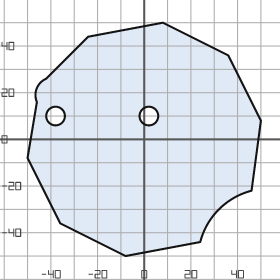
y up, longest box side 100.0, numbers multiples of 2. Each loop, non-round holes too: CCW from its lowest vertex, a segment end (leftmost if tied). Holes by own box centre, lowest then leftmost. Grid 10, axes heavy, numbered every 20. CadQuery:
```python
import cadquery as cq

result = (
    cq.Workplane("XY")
    .moveTo(-8.0, -50.0)
    .lineTo(24.0, -44.0)
    .threePointArc((32.0, -30.0), (46.0, -22.0))
    .lineTo(50.0, 8.0)
    .lineTo(36.0, 36.0)
    .lineTo(8.0, 50.0)
    .lineTo(-24.0, 44.0)
    .lineTo(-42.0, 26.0)
    .threePointArc((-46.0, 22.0), (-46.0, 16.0))
    .lineTo(-50.0, -8.0)
    .lineTo(-36.0, -36.0)
    .close()
    .moveTo(-38.0, 10.0)
    .circle(4.0)
    .moveTo(2.0, 10.0)
    .circle(4.0)
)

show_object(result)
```